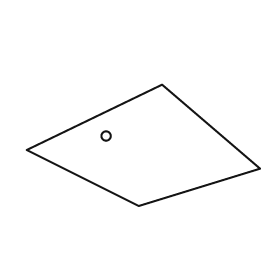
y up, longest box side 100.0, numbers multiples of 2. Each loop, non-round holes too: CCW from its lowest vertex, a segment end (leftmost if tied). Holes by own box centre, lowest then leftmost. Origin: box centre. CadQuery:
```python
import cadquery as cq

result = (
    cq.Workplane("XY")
    .moveTo(-2.0, -26.0)
    .lineTo(50.0, -10.0)
    .lineTo(8.0, 26.0)
    .lineTo(-50.0, -2.0)
    .close()
    .moveTo(-16.0, 4.0)
    .circle(2.0)
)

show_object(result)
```